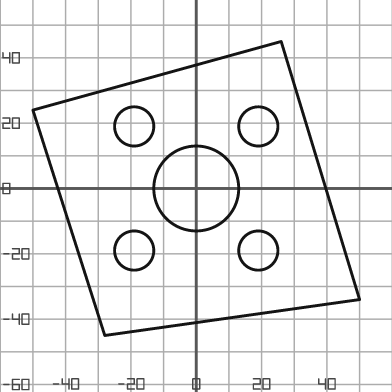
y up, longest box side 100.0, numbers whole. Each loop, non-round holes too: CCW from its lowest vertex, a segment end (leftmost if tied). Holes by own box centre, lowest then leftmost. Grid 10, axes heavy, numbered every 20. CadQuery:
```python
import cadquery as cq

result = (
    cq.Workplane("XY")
    .moveTo(-28.0, -45.0)
    .lineTo(50.0, -34.0)
    .lineTo(26.0, 45.0)
    .lineTo(-50.0, 24.0)
    .close()
    .moveTo(-19.0, -19.0)
    .circle(6.0)
    .moveTo(19.0, -19.0)
    .circle(6.0)
    .moveTo(0.0, 0.0)
    .circle(13.0)
    .moveTo(-19.0, 19.0)
    .circle(6.0)
    .moveTo(19.0, 19.0)
    .circle(6.0)
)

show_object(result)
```